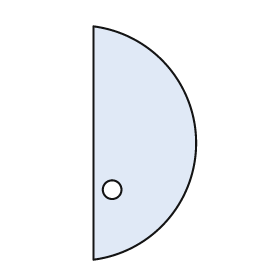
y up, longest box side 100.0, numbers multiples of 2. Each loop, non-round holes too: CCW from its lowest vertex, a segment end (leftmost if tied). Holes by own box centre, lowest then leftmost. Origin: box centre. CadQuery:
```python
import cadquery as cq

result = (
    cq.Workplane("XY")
    .moveTo(-22.0, -50.0)
    .threePointArc((22.0, 0.0), (-22.0, 50.0))
    .close()
    .moveTo(-14.0, -20.0)
    .circle(4.0)
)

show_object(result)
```